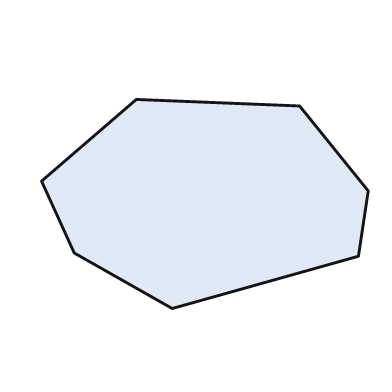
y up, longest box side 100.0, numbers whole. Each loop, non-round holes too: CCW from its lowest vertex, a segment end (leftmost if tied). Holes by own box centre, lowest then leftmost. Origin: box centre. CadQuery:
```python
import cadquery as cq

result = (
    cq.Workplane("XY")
    .moveTo(-10.0, -32.0)
    .lineTo(47.0, -16.0)
    .lineTo(50.0, 4.0)
    .lineTo(29.0, 30.0)
    .lineTo(-21.0, 32.0)
    .lineTo(-50.0, 7.0)
    .lineTo(-40.0, -15.0)
    .close()
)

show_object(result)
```